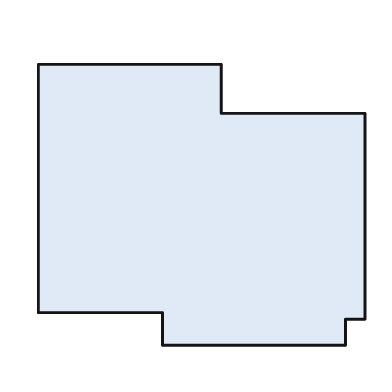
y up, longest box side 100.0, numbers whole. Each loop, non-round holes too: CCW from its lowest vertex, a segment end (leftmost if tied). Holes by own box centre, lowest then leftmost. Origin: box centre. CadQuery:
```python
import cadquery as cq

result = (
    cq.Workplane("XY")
    .moveTo(-12.0, -43.0)
    .lineTo(44.0, -43.0)
    .lineTo(44.0, -35.0)
    .lineTo(50.0, -35.0)
    .lineTo(50.0, 28.0)
    .lineTo(6.0, 28.0)
    .lineTo(6.0, 43.0)
    .lineTo(-50.0, 43.0)
    .lineTo(-50.0, -33.0)
    .lineTo(-12.0, -33.0)
    .close()
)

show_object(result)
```